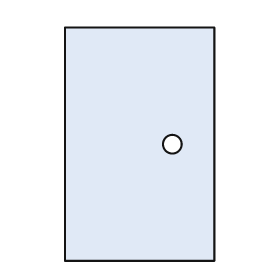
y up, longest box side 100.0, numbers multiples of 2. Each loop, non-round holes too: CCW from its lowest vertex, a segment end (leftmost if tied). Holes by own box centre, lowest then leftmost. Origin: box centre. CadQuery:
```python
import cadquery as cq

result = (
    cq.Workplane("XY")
    .moveTo(-32.0, -50.0)
    .lineTo(32.0, -50.0)
    .lineTo(32.0, 50.0)
    .lineTo(-32.0, 50.0)
    .close()
    .moveTo(14.0, 0.0)
    .circle(4.0)
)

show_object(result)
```